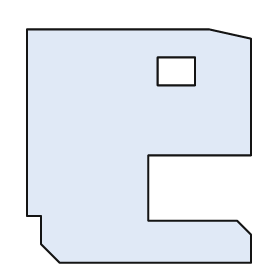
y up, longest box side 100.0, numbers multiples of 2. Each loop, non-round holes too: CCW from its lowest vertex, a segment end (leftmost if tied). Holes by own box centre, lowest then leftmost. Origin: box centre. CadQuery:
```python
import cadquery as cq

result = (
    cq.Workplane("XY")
    .moveTo(-34.0, -50.0)
    .lineTo(48.0, -50.0)
    .lineTo(48.0, -38.0)
    .lineTo(42.0, -32.0)
    .lineTo(4.0, -32.0)
    .lineTo(4.0, -4.0)
    .lineTo(48.0, -4.0)
    .lineTo(48.0, 46.0)
    .lineTo(30.0, 50.0)
    .lineTo(-48.0, 50.0)
    .lineTo(-48.0, -30.0)
    .lineTo(-42.0, -30.0)
    .lineTo(-42.0, -42.0)
    .close()
    .moveTo(8.0, 26.0)
    .lineTo(24.0, 26.0)
    .lineTo(24.0, 38.0)
    .lineTo(8.0, 38.0)
    .close()
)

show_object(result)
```